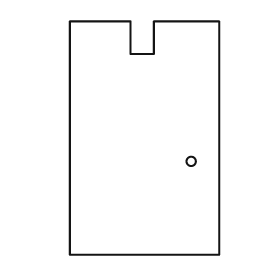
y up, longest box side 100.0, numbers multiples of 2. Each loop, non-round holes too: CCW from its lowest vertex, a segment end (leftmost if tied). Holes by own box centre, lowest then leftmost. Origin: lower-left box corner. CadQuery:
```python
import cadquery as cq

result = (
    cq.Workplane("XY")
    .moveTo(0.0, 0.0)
    .lineTo(64.0, 0.0)
    .lineTo(64.0, 100.0)
    .lineTo(36.0, 100.0)
    .lineTo(36.0, 86.0)
    .lineTo(26.0, 86.0)
    .lineTo(26.0, 100.0)
    .lineTo(0.0, 100.0)
    .close()
    .moveTo(52.0, 40.0)
    .circle(2.0)
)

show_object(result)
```